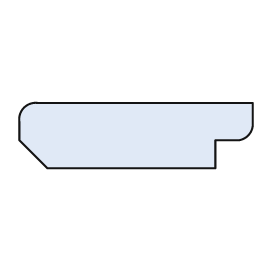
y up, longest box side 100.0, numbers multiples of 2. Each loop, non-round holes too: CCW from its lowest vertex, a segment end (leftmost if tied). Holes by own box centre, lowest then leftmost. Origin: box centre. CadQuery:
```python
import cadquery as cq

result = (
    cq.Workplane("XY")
    .moveTo(-38.0, -14.0)
    .lineTo(34.0, -14.0)
    .lineTo(34.0, -2.0)
    .lineTo(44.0, -2.0)
    .threePointArc((48.0, 0.0), (50.0, 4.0))
    .lineTo(50.0, 14.0)
    .lineTo(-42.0, 14.0)
    .threePointArc((-48.0, 12.0), (-50.0, 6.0))
    .lineTo(-50.0, -2.0)
    .close()
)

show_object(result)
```